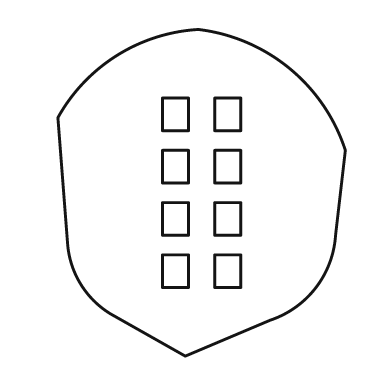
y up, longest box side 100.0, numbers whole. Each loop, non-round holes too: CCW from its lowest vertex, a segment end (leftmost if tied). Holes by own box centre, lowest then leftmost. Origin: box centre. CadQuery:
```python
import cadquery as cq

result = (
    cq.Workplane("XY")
    .moveTo(-5.0, -50.0)
    .lineTo(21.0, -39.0)
    .threePointArc((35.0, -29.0), (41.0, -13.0))
    .lineTo(44.0, 13.0)
    .threePointArc((27.0, 38.0), (-1.0, 50.0))
    .threePointArc((-26.0, 42.0), (-44.0, 23.0))
    .lineTo(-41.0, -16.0)
    .threePointArc((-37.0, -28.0), (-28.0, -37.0))
    .close()
    .moveTo(-12.0, -29.0)
    .lineTo(-4.0, -29.0)
    .lineTo(-4.0, -19.0)
    .lineTo(-12.0, -19.0)
    .close()
    .moveTo(4.0, -29.0)
    .lineTo(12.0, -29.0)
    .lineTo(12.0, -19.0)
    .lineTo(4.0, -19.0)
    .close()
    .moveTo(-12.0, -13.0)
    .lineTo(-4.0, -13.0)
    .lineTo(-4.0, -3.0)
    .lineTo(-12.0, -3.0)
    .close()
    .moveTo(4.0, -13.0)
    .lineTo(12.0, -13.0)
    .lineTo(12.0, -3.0)
    .lineTo(4.0, -3.0)
    .close()
    .moveTo(-12.0, 3.0)
    .lineTo(-4.0, 3.0)
    .lineTo(-4.0, 13.0)
    .lineTo(-12.0, 13.0)
    .close()
    .moveTo(4.0, 3.0)
    .lineTo(12.0, 3.0)
    .lineTo(12.0, 13.0)
    .lineTo(4.0, 13.0)
    .close()
    .moveTo(-12.0, 19.0)
    .lineTo(-4.0, 19.0)
    .lineTo(-4.0, 29.0)
    .lineTo(-12.0, 29.0)
    .close()
    .moveTo(4.0, 19.0)
    .lineTo(12.0, 19.0)
    .lineTo(12.0, 29.0)
    .lineTo(4.0, 29.0)
    .close()
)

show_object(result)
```